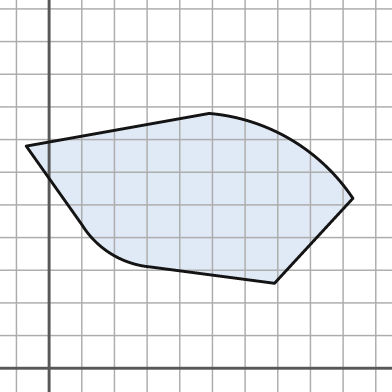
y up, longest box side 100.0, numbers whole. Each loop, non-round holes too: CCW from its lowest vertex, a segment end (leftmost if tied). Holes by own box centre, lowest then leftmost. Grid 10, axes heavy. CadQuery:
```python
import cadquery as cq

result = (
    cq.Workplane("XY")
    .moveTo(69.0, 26.0)
    .lineTo(93.0, 52.0)
    .threePointArc((74.0, 70.0), (49.0, 78.0))
    .lineTo(-7.0, 68.0)
    .lineTo(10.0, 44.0)
    .threePointArc((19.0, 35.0), (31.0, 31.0))
    .close()
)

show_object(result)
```